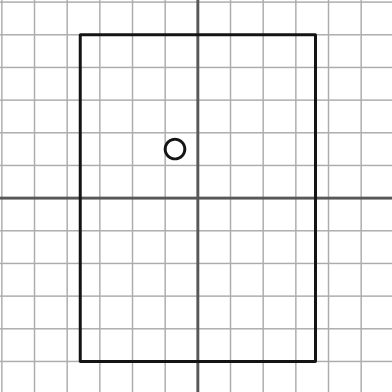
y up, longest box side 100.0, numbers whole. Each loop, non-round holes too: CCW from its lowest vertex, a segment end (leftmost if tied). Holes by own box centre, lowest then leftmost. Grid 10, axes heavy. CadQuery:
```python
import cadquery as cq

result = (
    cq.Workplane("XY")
    .moveTo(-36.0, -50.0)
    .lineTo(36.0, -50.0)
    .lineTo(36.0, 50.0)
    .lineTo(-36.0, 50.0)
    .close()
    .moveTo(-7.0, 15.0)
    .circle(3.0)
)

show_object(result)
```